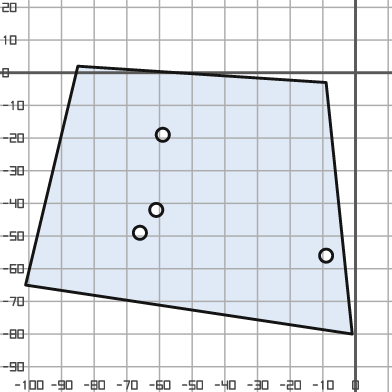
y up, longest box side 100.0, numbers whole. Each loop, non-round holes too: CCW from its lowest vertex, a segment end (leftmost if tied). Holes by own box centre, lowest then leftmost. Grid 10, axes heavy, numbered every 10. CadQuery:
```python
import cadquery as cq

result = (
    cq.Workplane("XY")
    .moveTo(-1.0, -80.0)
    .lineTo(-9.0, -3.0)
    .lineTo(-85.0, 2.0)
    .lineTo(-101.0, -65.0)
    .close()
    .moveTo(-9.0, -56.0)
    .circle(2.0)
    .moveTo(-66.0, -49.0)
    .circle(2.0)
    .moveTo(-61.0, -42.0)
    .circle(2.0)
    .moveTo(-59.0, -19.0)
    .circle(2.0)
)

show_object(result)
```